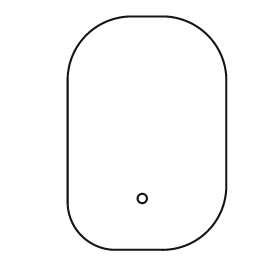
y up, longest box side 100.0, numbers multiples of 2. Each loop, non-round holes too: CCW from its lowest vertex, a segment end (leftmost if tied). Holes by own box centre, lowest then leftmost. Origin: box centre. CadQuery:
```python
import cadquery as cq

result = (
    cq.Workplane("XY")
    .moveTo(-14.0, -50.0)
    .lineTo(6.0, -50.0)
    .threePointArc((26.0, -42.0), (34.0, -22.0))
    .lineTo(34.0, 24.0)
    .threePointArc((26.0, 42.0), (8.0, 50.0))
    .lineTo(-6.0, 50.0)
    .threePointArc((-26.0, 42.0), (-34.0, 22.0))
    .lineTo(-34.0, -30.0)
    .threePointArc((-28.0, -44.0), (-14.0, -50.0))
    .close()
    .moveTo(-2.0, -28.0)
    .circle(2.0)
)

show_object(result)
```